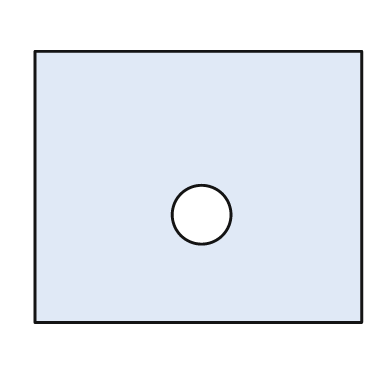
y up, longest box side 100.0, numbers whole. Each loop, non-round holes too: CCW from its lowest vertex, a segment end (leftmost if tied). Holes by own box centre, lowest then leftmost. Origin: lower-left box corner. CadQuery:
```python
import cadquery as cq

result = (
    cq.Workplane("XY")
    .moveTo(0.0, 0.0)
    .lineTo(100.0, 0.0)
    .lineTo(100.0, 83.0)
    .lineTo(0.0, 83.0)
    .close()
    .moveTo(51.0, 33.0)
    .circle(9.0)
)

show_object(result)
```